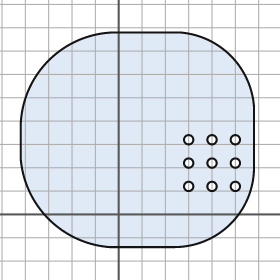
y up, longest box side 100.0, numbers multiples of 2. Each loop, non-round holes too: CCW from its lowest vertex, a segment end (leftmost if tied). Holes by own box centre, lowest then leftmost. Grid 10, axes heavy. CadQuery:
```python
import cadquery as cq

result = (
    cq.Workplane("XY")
    .moveTo(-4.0, -14.0)
    .lineTo(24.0, -14.0)
    .threePointArc((48.0, -4.0), (58.0, 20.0))
    .lineTo(58.0, 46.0)
    .threePointArc((48.0, 68.0), (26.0, 78.0))
    .lineTo(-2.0, 78.0)
    .threePointArc((-30.0, 66.0), (-42.0, 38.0))
    .lineTo(-42.0, 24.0)
    .threePointArc((-30.0, -2.0), (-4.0, -14.0))
    .close()
    .moveTo(30.0, 12.0)
    .circle(2.0)
    .moveTo(40.0, 12.0)
    .circle(2.0)
    .moveTo(50.0, 12.0)
    .circle(2.0)
    .moveTo(30.0, 22.0)
    .circle(2.0)
    .moveTo(40.0, 22.0)
    .circle(2.0)
    .moveTo(50.0, 22.0)
    .circle(2.0)
    .moveTo(30.0, 32.0)
    .circle(2.0)
    .moveTo(40.0, 32.0)
    .circle(2.0)
    .moveTo(50.0, 32.0)
    .circle(2.0)
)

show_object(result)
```